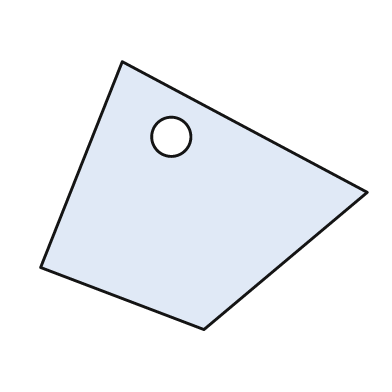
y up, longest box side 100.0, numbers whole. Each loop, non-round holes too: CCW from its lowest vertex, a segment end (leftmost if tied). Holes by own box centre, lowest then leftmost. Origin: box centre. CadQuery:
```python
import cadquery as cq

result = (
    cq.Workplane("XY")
    .moveTo(0.0, -41.0)
    .lineTo(50.0, 1.0)
    .lineTo(-25.0, 41.0)
    .lineTo(-50.0, -22.0)
    .close()
    .moveTo(-10.0, 18.0)
    .circle(6.0)
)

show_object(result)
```